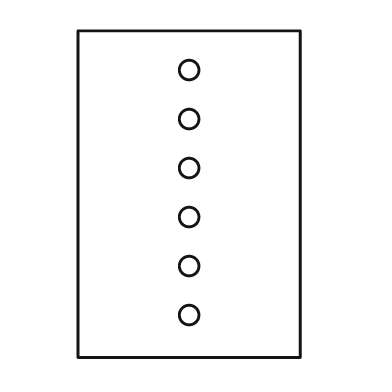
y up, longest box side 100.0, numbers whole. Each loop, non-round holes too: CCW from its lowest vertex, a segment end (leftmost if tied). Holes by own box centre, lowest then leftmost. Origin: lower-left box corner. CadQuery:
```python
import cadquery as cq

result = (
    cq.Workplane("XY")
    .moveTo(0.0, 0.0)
    .lineTo(68.0, 0.0)
    .lineTo(68.0, 100.0)
    .lineTo(0.0, 100.0)
    .close()
    .moveTo(34.0, 13.0)
    .circle(3.0)
    .moveTo(34.0, 28.0)
    .circle(3.0)
    .moveTo(34.0, 43.0)
    .circle(3.0)
    .moveTo(34.0, 58.0)
    .circle(3.0)
    .moveTo(34.0, 73.0)
    .circle(3.0)
    .moveTo(34.0, 88.0)
    .circle(3.0)
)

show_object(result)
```